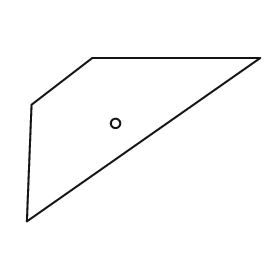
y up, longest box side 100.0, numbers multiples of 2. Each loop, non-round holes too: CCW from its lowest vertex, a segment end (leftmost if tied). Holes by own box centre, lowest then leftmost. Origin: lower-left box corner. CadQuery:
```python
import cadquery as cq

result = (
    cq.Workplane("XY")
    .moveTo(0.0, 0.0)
    .lineTo(100.0, 70.0)
    .lineTo(28.0, 70.0)
    .lineTo(2.0, 50.0)
    .close()
    .moveTo(38.0, 42.0)
    .circle(2.0)
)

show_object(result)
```